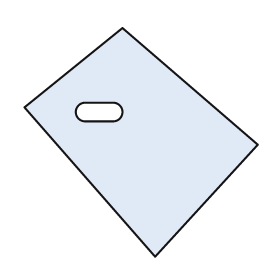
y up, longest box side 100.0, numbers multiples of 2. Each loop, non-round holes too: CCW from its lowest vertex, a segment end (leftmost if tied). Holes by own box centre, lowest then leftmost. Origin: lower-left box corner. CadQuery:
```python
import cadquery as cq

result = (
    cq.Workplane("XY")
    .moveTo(56.0, 0.0)
    .lineTo(100.0, 48.0)
    .lineTo(42.0, 98.0)
    .lineTo(0.0, 64.0)
    .close()
    .moveTo(26.0, 58.0)
    .lineTo(38.0, 58.0)
    .threePointArc((42.0, 62.0), (38.0, 66.0))
    .lineTo(26.0, 66.0)
    .threePointArc((22.0, 62.0), (26.0, 58.0))
    .close()
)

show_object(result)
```